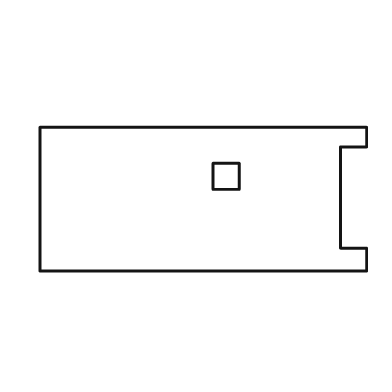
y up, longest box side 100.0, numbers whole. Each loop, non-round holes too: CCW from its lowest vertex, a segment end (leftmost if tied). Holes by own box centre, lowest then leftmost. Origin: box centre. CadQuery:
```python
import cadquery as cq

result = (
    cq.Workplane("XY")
    .moveTo(-50.0, -22.0)
    .lineTo(50.0, -22.0)
    .lineTo(50.0, -15.0)
    .lineTo(42.0, -15.0)
    .lineTo(42.0, 16.0)
    .lineTo(50.0, 16.0)
    .lineTo(50.0, 22.0)
    .lineTo(-50.0, 22.0)
    .close()
    .moveTo(3.0, 3.0)
    .lineTo(11.0, 3.0)
    .lineTo(11.0, 11.0)
    .lineTo(3.0, 11.0)
    .close()
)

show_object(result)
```